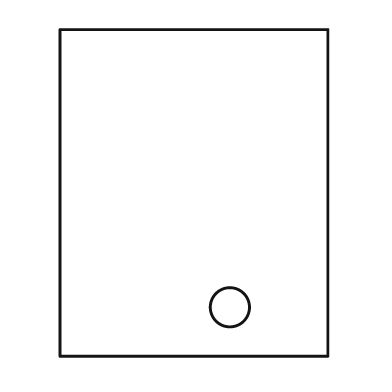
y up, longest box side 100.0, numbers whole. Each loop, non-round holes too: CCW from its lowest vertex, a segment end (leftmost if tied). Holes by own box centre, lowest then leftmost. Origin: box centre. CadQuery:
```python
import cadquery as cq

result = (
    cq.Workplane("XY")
    .moveTo(-41.0, -50.0)
    .lineTo(41.0, -50.0)
    .lineTo(41.0, 50.0)
    .lineTo(-41.0, 50.0)
    .close()
    .moveTo(11.0, -35.0)
    .circle(6.0)
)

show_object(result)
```